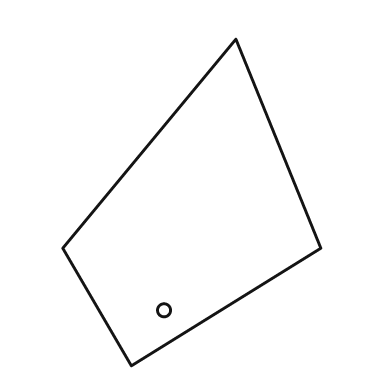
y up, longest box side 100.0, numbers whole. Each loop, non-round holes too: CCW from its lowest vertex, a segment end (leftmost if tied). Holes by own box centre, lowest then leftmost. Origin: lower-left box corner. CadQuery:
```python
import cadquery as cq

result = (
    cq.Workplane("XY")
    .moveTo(21.0, 0.0)
    .lineTo(79.0, 36.0)
    .lineTo(53.0, 100.0)
    .lineTo(0.0, 36.0)
    .close()
    .moveTo(31.0, 17.0)
    .circle(2.0)
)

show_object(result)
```